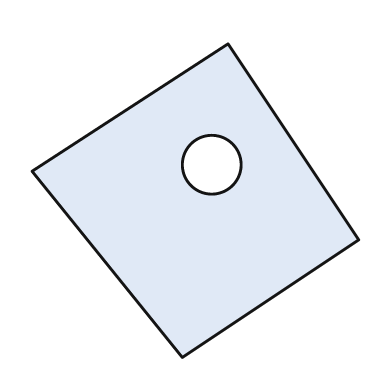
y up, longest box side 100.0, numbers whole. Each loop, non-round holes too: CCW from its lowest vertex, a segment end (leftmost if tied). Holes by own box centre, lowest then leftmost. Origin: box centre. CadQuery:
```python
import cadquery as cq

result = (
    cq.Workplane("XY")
    .moveTo(-4.0, -48.0)
    .lineTo(50.0, -12.0)
    .lineTo(10.0, 48.0)
    .lineTo(-50.0, 9.0)
    .close()
    .moveTo(5.0, 11.0)
    .circle(9.0)
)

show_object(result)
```